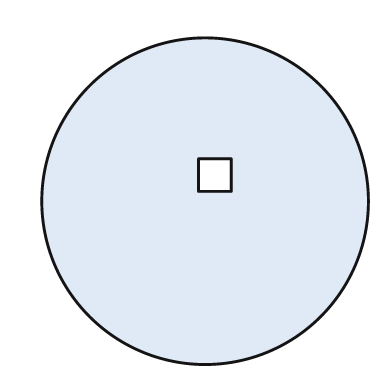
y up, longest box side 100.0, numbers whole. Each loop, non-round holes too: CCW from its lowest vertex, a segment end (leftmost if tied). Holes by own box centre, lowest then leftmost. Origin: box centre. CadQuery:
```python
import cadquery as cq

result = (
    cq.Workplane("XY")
    .moveTo(0.0, 0.0)
    .circle(50.0)
    .moveTo(-2.0, 3.0)
    .lineTo(8.0, 3.0)
    .lineTo(8.0, 13.0)
    .lineTo(-2.0, 13.0)
    .close()
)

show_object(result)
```